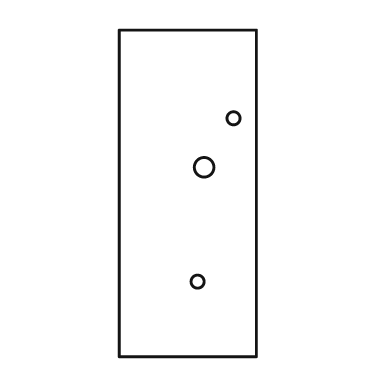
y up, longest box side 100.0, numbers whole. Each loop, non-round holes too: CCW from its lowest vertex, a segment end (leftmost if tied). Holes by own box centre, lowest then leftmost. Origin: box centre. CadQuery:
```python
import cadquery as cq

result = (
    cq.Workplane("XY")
    .moveTo(-21.0, -50.0)
    .lineTo(21.0, -50.0)
    .lineTo(21.0, 50.0)
    .lineTo(-21.0, 50.0)
    .close()
    .moveTo(3.0, -27.0)
    .circle(2.0)
    .moveTo(5.0, 8.0)
    .circle(3.0)
    .moveTo(14.0, 23.0)
    .circle(2.0)
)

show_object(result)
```